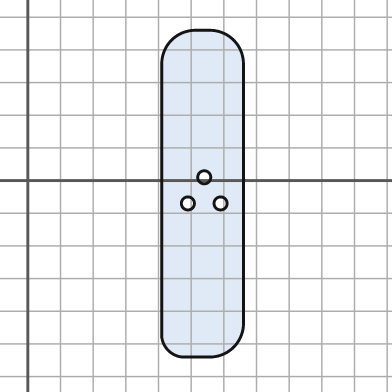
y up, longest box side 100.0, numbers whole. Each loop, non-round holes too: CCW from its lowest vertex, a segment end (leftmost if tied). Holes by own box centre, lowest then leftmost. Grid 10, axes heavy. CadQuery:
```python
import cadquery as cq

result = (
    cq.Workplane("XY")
    .moveTo(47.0, -54.0)
    .lineTo(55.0, -54.0)
    .threePointArc((63.0, -51.0), (66.0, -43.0))
    .lineTo(66.0, 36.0)
    .threePointArc((63.0, 43.0), (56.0, 46.0))
    .lineTo(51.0, 46.0)
    .threePointArc((44.0, 43.0), (41.0, 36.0))
    .lineTo(41.0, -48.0)
    .threePointArc((43.0, -52.0), (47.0, -54.0))
    .close()
    .moveTo(49.0, -7.0)
    .circle(2.0)
    .moveTo(59.0, -7.0)
    .circle(2.0)
    .moveTo(54.0, 1.0)
    .circle(2.0)
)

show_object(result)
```